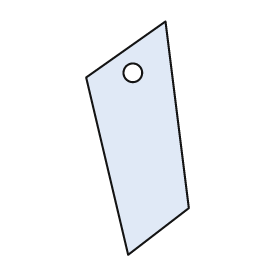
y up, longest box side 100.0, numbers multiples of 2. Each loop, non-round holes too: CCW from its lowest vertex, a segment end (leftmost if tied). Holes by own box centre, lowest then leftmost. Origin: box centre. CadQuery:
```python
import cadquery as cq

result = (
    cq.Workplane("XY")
    .moveTo(-4.0, -50.0)
    .lineTo(22.0, -30.0)
    .lineTo(12.0, 50.0)
    .lineTo(-22.0, 26.0)
    .close()
    .moveTo(-2.0, 28.0)
    .circle(4.0)
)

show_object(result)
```